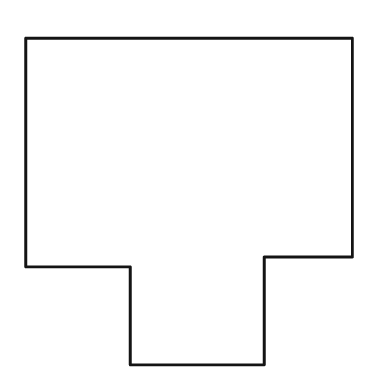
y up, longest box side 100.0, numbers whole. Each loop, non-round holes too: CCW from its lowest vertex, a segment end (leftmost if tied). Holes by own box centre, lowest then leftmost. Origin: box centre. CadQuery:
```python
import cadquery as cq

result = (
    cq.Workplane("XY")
    .moveTo(-18.0, -50.0)
    .lineTo(23.0, -50.0)
    .lineTo(23.0, -17.0)
    .lineTo(50.0, -17.0)
    .lineTo(50.0, 50.0)
    .lineTo(-50.0, 50.0)
    .lineTo(-50.0, -20.0)
    .lineTo(-18.0, -20.0)
    .close()
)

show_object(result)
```